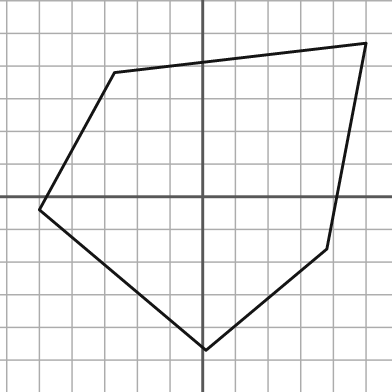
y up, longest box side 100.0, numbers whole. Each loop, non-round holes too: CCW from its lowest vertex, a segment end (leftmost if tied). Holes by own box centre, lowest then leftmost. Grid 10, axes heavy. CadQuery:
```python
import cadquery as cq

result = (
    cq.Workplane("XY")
    .moveTo(1.0, -47.0)
    .lineTo(38.0, -16.0)
    .lineTo(50.0, 47.0)
    .lineTo(-27.0, 38.0)
    .lineTo(-50.0, -4.0)
    .close()
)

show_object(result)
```